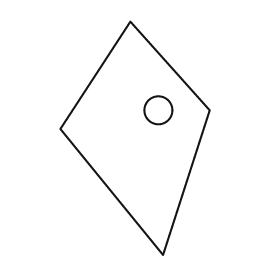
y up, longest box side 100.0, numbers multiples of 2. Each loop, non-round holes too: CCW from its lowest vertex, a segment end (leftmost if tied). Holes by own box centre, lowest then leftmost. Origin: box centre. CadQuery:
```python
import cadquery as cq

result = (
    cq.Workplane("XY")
    .moveTo(12.0, -50.0)
    .lineTo(32.0, 12.0)
    .lineTo(-2.0, 50.0)
    .lineTo(-32.0, 4.0)
    .close()
    .moveTo(10.0, 12.0)
    .circle(6.0)
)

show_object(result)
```